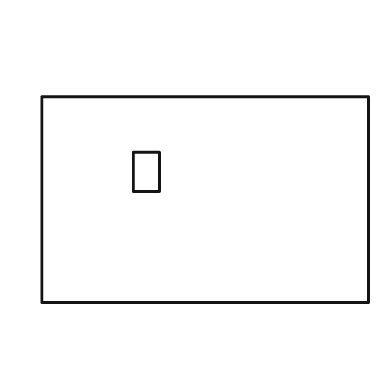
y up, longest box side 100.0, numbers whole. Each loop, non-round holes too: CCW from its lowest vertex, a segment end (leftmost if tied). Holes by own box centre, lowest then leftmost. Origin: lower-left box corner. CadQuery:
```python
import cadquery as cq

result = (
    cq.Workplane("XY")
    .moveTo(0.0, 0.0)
    .lineTo(100.0, 0.0)
    .lineTo(100.0, 63.0)
    .lineTo(0.0, 63.0)
    .close()
    .moveTo(28.0, 34.0)
    .lineTo(36.0, 34.0)
    .lineTo(36.0, 46.0)
    .lineTo(28.0, 46.0)
    .close()
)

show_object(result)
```